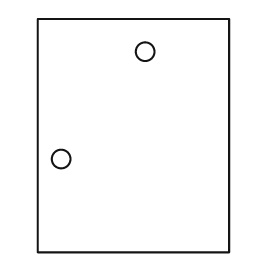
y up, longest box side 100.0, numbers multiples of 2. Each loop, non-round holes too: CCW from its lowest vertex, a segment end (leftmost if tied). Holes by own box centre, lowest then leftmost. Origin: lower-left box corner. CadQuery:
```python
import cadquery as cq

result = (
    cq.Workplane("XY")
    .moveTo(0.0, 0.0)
    .lineTo(82.0, 0.0)
    .lineTo(82.0, 100.0)
    .lineTo(0.0, 100.0)
    .close()
    .moveTo(10.0, 40.0)
    .circle(4.0)
    .moveTo(46.0, 86.0)
    .circle(4.0)
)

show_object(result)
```